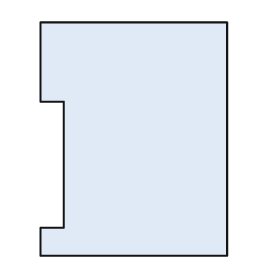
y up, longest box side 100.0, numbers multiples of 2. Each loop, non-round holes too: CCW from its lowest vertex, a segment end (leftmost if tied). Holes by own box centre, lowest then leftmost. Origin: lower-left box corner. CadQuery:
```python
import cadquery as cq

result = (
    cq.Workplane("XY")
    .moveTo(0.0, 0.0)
    .lineTo(80.0, 0.0)
    .lineTo(80.0, 100.0)
    .lineTo(0.0, 100.0)
    .lineTo(0.0, 66.0)
    .lineTo(10.0, 66.0)
    .lineTo(10.0, 12.0)
    .lineTo(0.0, 12.0)
    .close()
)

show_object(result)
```